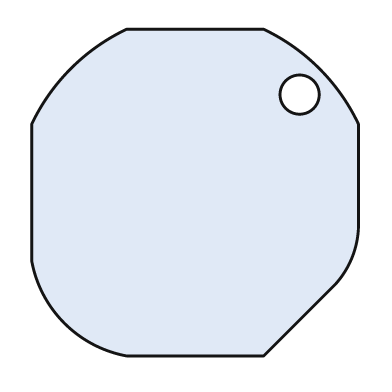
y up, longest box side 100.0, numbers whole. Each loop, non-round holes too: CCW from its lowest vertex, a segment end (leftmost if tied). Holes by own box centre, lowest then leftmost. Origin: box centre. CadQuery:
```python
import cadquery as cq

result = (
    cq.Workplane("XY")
    .moveTo(-21.0, -50.0)
    .lineTo(21.0, -50.0)
    .lineTo(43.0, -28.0)
    .threePointArc((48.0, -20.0), (50.0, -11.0))
    .lineTo(50.0, 21.0)
    .threePointArc((38.0, 38.0), (21.0, 50.0))
    .lineTo(-21.0, 50.0)
    .threePointArc((-38.0, 38.0), (-50.0, 21.0))
    .lineTo(-50.0, -21.0)
    .threePointArc((-40.0, -40.0), (-21.0, -50.0))
    .close()
    .moveTo(32.0, 30.0)
    .circle(6.0)
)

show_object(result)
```